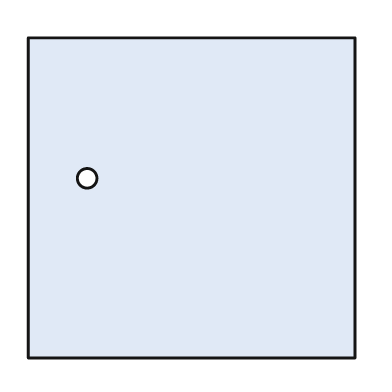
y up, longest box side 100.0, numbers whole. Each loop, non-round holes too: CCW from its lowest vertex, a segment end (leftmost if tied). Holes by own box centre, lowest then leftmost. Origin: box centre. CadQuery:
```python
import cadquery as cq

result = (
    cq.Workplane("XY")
    .moveTo(-50.0, -49.0)
    .lineTo(50.0, -49.0)
    .lineTo(50.0, 49.0)
    .lineTo(-50.0, 49.0)
    .close()
    .moveTo(-32.0, 6.0)
    .circle(3.0)
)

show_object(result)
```